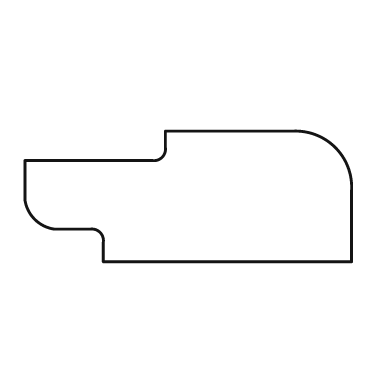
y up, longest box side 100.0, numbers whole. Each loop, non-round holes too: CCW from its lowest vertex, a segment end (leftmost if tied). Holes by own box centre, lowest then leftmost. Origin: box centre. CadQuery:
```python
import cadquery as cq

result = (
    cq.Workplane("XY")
    .moveTo(-26.0, -20.0)
    .lineTo(50.0, -20.0)
    .lineTo(50.0, 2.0)
    .threePointArc((45.0, 15.0), (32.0, 20.0))
    .lineTo(-7.0, 20.0)
    .lineTo(-7.0, 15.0)
    .threePointArc((-8.0, 12.0), (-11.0, 11.0))
    .lineTo(-50.0, 11.0)
    .lineTo(-50.0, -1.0)
    .threePointArc((-47.0, -7.0), (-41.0, -10.0))
    .lineTo(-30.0, -10.0)
    .threePointArc((-27.0, -11.0), (-26.0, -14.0))
    .close()
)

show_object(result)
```